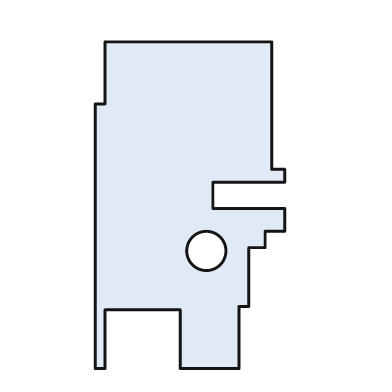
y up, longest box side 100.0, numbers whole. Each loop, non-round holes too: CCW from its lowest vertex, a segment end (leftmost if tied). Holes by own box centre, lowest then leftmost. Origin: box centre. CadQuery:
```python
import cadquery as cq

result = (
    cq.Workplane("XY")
    .moveTo(-29.0, -50.0)
    .lineTo(-26.0, -50.0)
    .lineTo(-26.0, -32.0)
    .lineTo(-3.0, -32.0)
    .lineTo(-3.0, -50.0)
    .lineTo(15.0, -50.0)
    .lineTo(15.0, -31.0)
    .lineTo(18.0, -31.0)
    .lineTo(18.0, -13.0)
    .lineTo(23.0, -13.0)
    .lineTo(23.0, -8.0)
    .lineTo(29.0, -8.0)
    .lineTo(29.0, -1.0)
    .lineTo(7.0, -1.0)
    .lineTo(7.0, 7.0)
    .lineTo(29.0, 7.0)
    .lineTo(29.0, 11.0)
    .lineTo(25.0, 11.0)
    .lineTo(25.0, 50.0)
    .lineTo(-26.0, 50.0)
    .lineTo(-26.0, 31.0)
    .lineTo(-29.0, 31.0)
    .close()
    .moveTo(5.0, -14.0)
    .circle(6.0)
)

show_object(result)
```